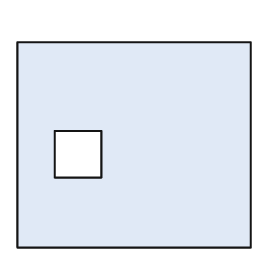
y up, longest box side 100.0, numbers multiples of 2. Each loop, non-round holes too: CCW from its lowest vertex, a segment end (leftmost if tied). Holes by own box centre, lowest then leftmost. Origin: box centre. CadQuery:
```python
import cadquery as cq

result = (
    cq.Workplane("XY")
    .moveTo(-50.0, -44.0)
    .lineTo(50.0, -44.0)
    .lineTo(50.0, 44.0)
    .lineTo(-50.0, 44.0)
    .close()
    .moveTo(-34.0, -14.0)
    .lineTo(-14.0, -14.0)
    .lineTo(-14.0, 6.0)
    .lineTo(-34.0, 6.0)
    .close()
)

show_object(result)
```